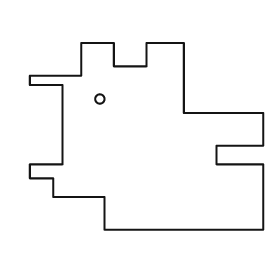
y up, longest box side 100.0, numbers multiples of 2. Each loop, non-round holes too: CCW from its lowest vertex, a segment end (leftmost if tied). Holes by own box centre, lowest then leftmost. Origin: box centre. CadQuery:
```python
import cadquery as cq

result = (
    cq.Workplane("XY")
    .moveTo(-18.0, -40.0)
    .lineTo(50.0, -40.0)
    .lineTo(50.0, -12.0)
    .lineTo(30.0, -12.0)
    .lineTo(30.0, -4.0)
    .lineTo(50.0, -4.0)
    .lineTo(50.0, 10.0)
    .lineTo(16.0, 10.0)
    .lineTo(16.0, 40.0)
    .lineTo(0.0, 40.0)
    .lineTo(0.0, 30.0)
    .lineTo(-14.0, 30.0)
    .lineTo(-14.0, 40.0)
    .lineTo(-28.0, 40.0)
    .lineTo(-28.0, 26.0)
    .lineTo(-50.0, 26.0)
    .lineTo(-50.0, 22.0)
    .lineTo(-36.0, 22.0)
    .lineTo(-36.0, -12.0)
    .lineTo(-50.0, -12.0)
    .lineTo(-50.0, -18.0)
    .lineTo(-40.0, -18.0)
    .lineTo(-40.0, -26.0)
    .lineTo(-18.0, -26.0)
    .close()
    .moveTo(-20.0, 16.0)
    .circle(2.0)
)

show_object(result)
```